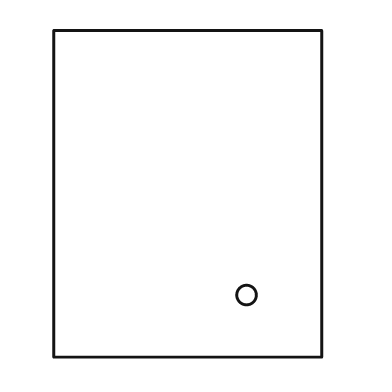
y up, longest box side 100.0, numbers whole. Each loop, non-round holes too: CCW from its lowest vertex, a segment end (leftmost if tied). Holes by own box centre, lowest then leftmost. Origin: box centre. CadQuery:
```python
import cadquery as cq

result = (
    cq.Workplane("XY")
    .moveTo(-41.0, -50.0)
    .lineTo(41.0, -50.0)
    .lineTo(41.0, 50.0)
    .lineTo(-41.0, 50.0)
    .close()
    .moveTo(18.0, -31.0)
    .circle(3.0)
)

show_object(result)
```